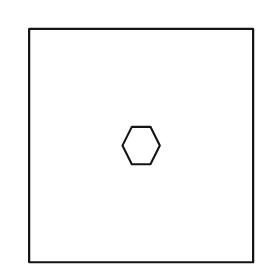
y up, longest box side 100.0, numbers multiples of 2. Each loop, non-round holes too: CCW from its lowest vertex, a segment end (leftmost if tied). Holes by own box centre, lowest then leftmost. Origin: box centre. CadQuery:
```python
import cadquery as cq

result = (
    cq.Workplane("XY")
    .moveTo(-48.0, -50.0)
    .lineTo(48.0, -50.0)
    .lineTo(48.0, 50.0)
    .lineTo(-48.0, 50.0)
    .close()
    .moveTo(-4.0, -8.0)
    .lineTo(4.0, -8.0)
    .lineTo(8.0, 0.0)
    .lineTo(4.0, 8.0)
    .lineTo(-4.0, 8.0)
    .lineTo(-8.0, 0.0)
    .close()
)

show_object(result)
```